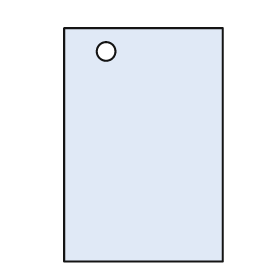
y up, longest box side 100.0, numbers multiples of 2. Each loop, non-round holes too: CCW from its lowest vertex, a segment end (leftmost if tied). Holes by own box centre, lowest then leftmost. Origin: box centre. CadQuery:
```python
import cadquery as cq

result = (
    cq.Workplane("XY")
    .moveTo(-34.0, -50.0)
    .lineTo(34.0, -50.0)
    .lineTo(34.0, 50.0)
    .lineTo(-34.0, 50.0)
    .close()
    .moveTo(-16.0, 40.0)
    .circle(4.0)
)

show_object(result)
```